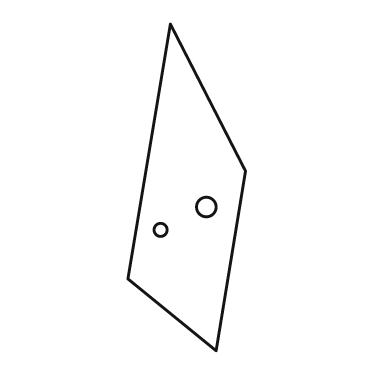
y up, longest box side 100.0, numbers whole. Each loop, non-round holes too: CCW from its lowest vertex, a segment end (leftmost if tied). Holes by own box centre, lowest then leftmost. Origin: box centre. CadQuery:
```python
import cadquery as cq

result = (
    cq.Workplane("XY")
    .moveTo(9.0, -50.0)
    .lineTo(18.0, 5.0)
    .lineTo(-5.0, 50.0)
    .lineTo(-18.0, -28.0)
    .close()
    .moveTo(-8.0, -13.0)
    .circle(2.0)
    .moveTo(6.0, -6.0)
    .circle(3.0)
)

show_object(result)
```